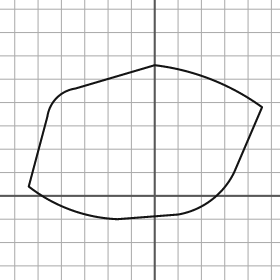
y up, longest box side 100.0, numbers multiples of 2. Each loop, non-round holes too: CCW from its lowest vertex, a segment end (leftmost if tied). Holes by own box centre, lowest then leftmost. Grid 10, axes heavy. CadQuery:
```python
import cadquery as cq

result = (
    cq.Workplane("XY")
    .moveTo(-16.0, -10.0)
    .lineTo(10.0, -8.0)
    .threePointArc((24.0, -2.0), (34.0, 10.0))
    .lineTo(46.0, 38.0)
    .threePointArc((24.0, 50.0), (0.0, 56.0))
    .lineTo(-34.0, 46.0)
    .threePointArc((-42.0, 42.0), (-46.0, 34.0))
    .lineTo(-54.0, 4.0)
    .threePointArc((-36.0, -6.0), (-16.0, -10.0))
    .close()
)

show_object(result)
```